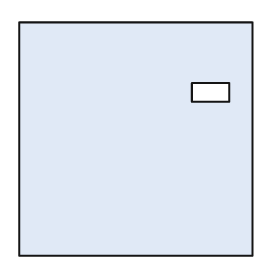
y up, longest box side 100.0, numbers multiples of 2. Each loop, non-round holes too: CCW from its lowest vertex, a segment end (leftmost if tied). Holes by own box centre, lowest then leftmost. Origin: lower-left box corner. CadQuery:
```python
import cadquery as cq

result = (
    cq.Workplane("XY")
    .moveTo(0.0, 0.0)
    .lineTo(100.0, 0.0)
    .lineTo(100.0, 100.0)
    .lineTo(0.0, 100.0)
    .close()
    .moveTo(74.0, 66.0)
    .lineTo(90.0, 66.0)
    .lineTo(90.0, 74.0)
    .lineTo(74.0, 74.0)
    .close()
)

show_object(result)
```